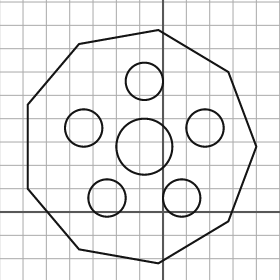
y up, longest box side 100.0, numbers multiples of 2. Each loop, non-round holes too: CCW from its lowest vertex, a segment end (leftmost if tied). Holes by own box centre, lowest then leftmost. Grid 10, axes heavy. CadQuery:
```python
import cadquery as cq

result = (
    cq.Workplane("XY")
    .moveTo(-2.0, -22.0)
    .lineTo(28.0, -4.0)
    .lineTo(40.0, 28.0)
    .lineTo(28.0, 60.0)
    .lineTo(-2.0, 78.0)
    .lineTo(-36.0, 72.0)
    .lineTo(-58.0, 46.0)
    .lineTo(-58.0, 10.0)
    .lineTo(-36.0, -16.0)
    .close()
    .moveTo(-24.0, 6.0)
    .circle(8.0)
    .moveTo(8.0, 6.0)
    .circle(8.0)
    .moveTo(-8.0, 28.0)
    .circle(12.0)
    .moveTo(-34.0, 36.0)
    .circle(8.0)
    .moveTo(18.0, 36.0)
    .circle(8.0)
    .moveTo(-8.0, 56.0)
    .circle(8.0)
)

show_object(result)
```